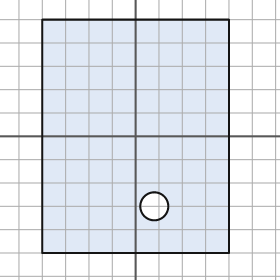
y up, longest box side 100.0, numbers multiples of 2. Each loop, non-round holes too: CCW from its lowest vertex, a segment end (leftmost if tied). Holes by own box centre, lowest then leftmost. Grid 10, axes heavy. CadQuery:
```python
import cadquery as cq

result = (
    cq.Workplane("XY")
    .moveTo(-40.0, -50.0)
    .lineTo(40.0, -50.0)
    .lineTo(40.0, 50.0)
    .lineTo(-40.0, 50.0)
    .close()
    .moveTo(8.0, -30.0)
    .circle(6.0)
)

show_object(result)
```